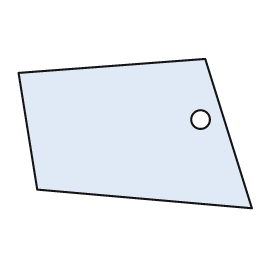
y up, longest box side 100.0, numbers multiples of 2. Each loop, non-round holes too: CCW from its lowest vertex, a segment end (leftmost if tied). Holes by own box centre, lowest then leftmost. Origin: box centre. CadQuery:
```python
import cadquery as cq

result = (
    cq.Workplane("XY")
    .moveTo(50.0, -32.0)
    .lineTo(30.0, 32.0)
    .lineTo(-50.0, 26.0)
    .lineTo(-42.0, -24.0)
    .close()
    .moveTo(28.0, 6.0)
    .circle(4.0)
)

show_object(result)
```